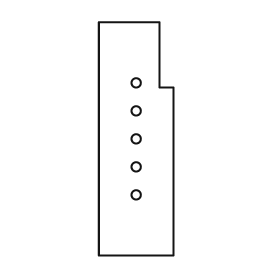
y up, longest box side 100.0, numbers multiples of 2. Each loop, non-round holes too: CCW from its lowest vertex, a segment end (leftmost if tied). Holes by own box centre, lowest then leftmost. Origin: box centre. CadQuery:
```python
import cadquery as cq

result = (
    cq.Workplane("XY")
    .moveTo(-16.0, -50.0)
    .lineTo(16.0, -50.0)
    .lineTo(16.0, 22.0)
    .lineTo(10.0, 22.0)
    .lineTo(10.0, 50.0)
    .lineTo(-16.0, 50.0)
    .close()
    .moveTo(0.0, -24.0)
    .circle(2.0)
    .moveTo(0.0, -12.0)
    .circle(2.0)
    .moveTo(0.0, 0.0)
    .circle(2.0)
    .moveTo(0.0, 12.0)
    .circle(2.0)
    .moveTo(0.0, 24.0)
    .circle(2.0)
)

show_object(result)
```